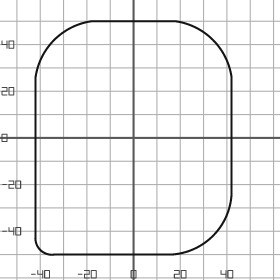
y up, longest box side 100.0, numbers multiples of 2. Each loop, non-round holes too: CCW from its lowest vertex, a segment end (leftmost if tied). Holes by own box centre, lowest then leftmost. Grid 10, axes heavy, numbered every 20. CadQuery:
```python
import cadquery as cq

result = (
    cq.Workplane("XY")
    .moveTo(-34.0, -50.0)
    .lineTo(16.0, -50.0)
    .threePointArc((34.0, -42.0), (42.0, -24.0))
    .lineTo(42.0, 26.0)
    .threePointArc((34.0, 42.0), (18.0, 50.0))
    .lineTo(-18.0, 50.0)
    .threePointArc((-34.0, 42.0), (-42.0, 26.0))
    .lineTo(-42.0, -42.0)
    .threePointArc((-40.0, -48.0), (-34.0, -50.0))
    .close()
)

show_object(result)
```